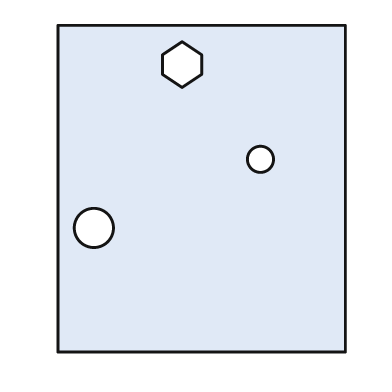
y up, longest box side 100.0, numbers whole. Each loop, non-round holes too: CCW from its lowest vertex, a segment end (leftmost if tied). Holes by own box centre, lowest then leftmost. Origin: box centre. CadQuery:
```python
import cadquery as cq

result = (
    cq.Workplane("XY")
    .moveTo(-44.0, -50.0)
    .lineTo(44.0, -50.0)
    .lineTo(44.0, 50.0)
    .lineTo(-44.0, 50.0)
    .close()
    .moveTo(-33.0, -12.0)
    .circle(6.0)
    .moveTo(18.0, 9.0)
    .circle(4.0)
    .moveTo(-6.0, 31.0)
    .lineTo(0.0, 35.0)
    .lineTo(0.0, 41.0)
    .lineTo(-6.0, 45.0)
    .lineTo(-12.0, 41.0)
    .lineTo(-12.0, 35.0)
    .close()
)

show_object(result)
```